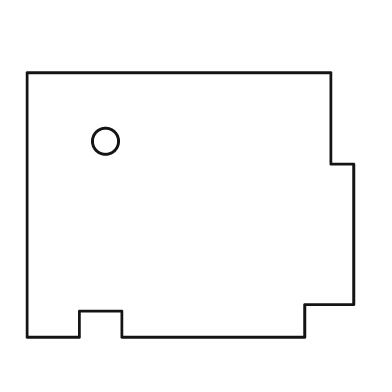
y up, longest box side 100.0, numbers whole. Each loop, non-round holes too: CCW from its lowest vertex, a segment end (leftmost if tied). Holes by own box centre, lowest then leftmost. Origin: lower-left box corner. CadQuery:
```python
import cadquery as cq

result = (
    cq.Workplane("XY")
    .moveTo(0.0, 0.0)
    .lineTo(16.0, 0.0)
    .lineTo(16.0, 8.0)
    .lineTo(29.0, 8.0)
    .lineTo(29.0, 0.0)
    .lineTo(85.0, 0.0)
    .lineTo(85.0, 10.0)
    .lineTo(100.0, 10.0)
    .lineTo(100.0, 53.0)
    .lineTo(93.0, 53.0)
    .lineTo(93.0, 81.0)
    .lineTo(0.0, 81.0)
    .close()
    .moveTo(24.0, 60.0)
    .circle(4.0)
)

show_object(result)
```